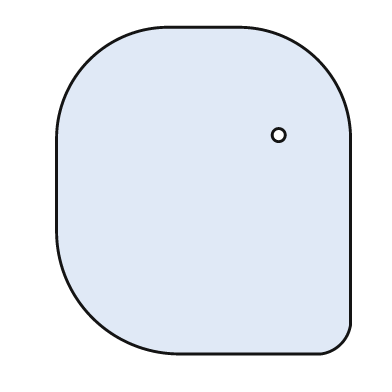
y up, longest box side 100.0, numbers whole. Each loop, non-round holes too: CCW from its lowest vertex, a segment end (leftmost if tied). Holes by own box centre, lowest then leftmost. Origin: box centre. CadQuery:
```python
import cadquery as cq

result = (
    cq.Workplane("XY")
    .moveTo(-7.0, -50.0)
    .lineTo(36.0, -50.0)
    .threePointArc((42.0, -47.0), (45.0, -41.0))
    .lineTo(45.0, 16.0)
    .threePointArc((35.0, 40.0), (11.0, 50.0))
    .lineTo(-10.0, 50.0)
    .threePointArc((-35.0, 40.0), (-45.0, 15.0))
    .lineTo(-45.0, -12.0)
    .threePointArc((-34.0, -39.0), (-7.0, -50.0))
    .close()
    .moveTo(23.0, 17.0)
    .circle(2.0)
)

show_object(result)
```